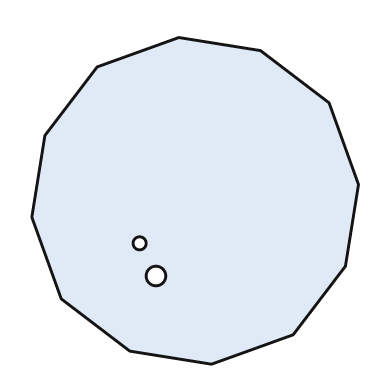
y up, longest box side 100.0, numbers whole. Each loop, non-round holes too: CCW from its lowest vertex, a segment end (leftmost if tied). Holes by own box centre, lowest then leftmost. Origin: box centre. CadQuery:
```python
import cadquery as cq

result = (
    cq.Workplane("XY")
    .moveTo(5.0, -50.0)
    .lineTo(30.0, -41.0)
    .lineTo(46.0, -20.0)
    .lineTo(50.0, 5.0)
    .lineTo(41.0, 30.0)
    .lineTo(20.0, 46.0)
    .lineTo(-5.0, 50.0)
    .lineTo(-30.0, 41.0)
    .lineTo(-46.0, 20.0)
    .lineTo(-50.0, -5.0)
    .lineTo(-41.0, -30.0)
    .lineTo(-20.0, -46.0)
    .close()
    .moveTo(-12.0, -23.0)
    .circle(3.0)
    .moveTo(-17.0, -13.0)
    .circle(2.0)
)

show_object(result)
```